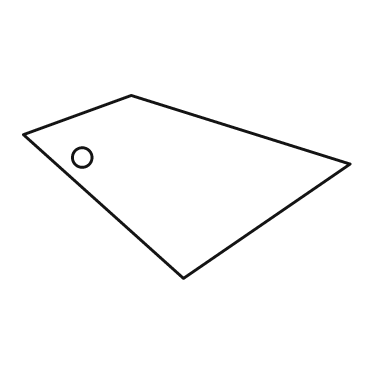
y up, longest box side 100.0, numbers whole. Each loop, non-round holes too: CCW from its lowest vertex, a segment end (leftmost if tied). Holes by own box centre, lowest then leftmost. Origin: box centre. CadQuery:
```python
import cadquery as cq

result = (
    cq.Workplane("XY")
    .moveTo(-1.0, -28.0)
    .lineTo(50.0, 7.0)
    .lineTo(-17.0, 28.0)
    .lineTo(-50.0, 16.0)
    .close()
    .moveTo(-32.0, 9.0)
    .circle(3.0)
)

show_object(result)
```